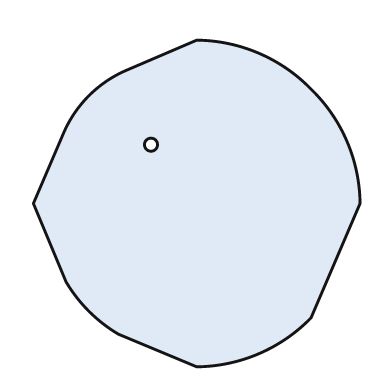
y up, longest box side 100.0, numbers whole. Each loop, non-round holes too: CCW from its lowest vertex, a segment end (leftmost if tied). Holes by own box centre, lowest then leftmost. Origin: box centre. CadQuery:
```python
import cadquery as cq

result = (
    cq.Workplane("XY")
    .moveTo(0.0, -50.0)
    .threePointArc((19.0, -46.0), (35.0, -35.0))
    .lineTo(50.0, 0.0)
    .threePointArc((46.0, 19.0), (35.0, 35.0))
    .threePointArc((19.0, 46.0), (0.0, 50.0))
    .lineTo(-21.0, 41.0)
    .threePointArc((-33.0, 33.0), (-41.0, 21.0))
    .lineTo(-50.0, 0.0)
    .lineTo(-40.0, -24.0)
    .threePointArc((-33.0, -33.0), (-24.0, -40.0))
    .close()
    .moveTo(-14.0, 18.0)
    .circle(2.0)
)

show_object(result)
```